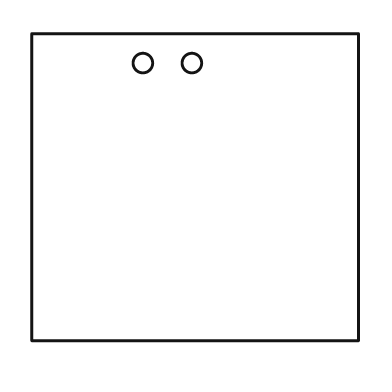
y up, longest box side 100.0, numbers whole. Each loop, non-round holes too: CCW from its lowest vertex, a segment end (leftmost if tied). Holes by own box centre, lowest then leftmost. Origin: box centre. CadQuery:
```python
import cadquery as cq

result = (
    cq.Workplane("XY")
    .moveTo(-50.0, -47.0)
    .lineTo(50.0, -47.0)
    .lineTo(50.0, 47.0)
    .lineTo(-50.0, 47.0)
    .close()
    .moveTo(-16.0, 38.0)
    .circle(3.0)
    .moveTo(-1.0, 38.0)
    .circle(3.0)
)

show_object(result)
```